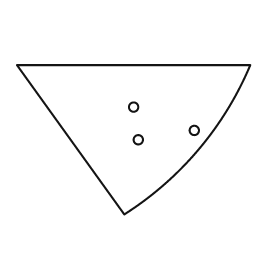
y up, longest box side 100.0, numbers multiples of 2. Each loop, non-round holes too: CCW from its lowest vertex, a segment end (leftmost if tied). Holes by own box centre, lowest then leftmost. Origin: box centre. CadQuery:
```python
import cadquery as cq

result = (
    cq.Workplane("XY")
    .moveTo(-4.0, -32.0)
    .threePointArc((28.0, -4.0), (50.0, 32.0))
    .lineTo(-50.0, 32.0)
    .close()
    .moveTo(2.0, 0.0)
    .circle(2.0)
    .moveTo(26.0, 4.0)
    .circle(2.0)
    .moveTo(0.0, 14.0)
    .circle(2.0)
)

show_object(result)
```